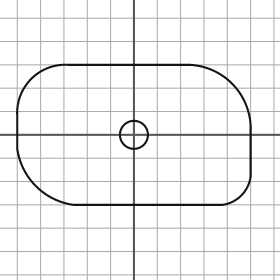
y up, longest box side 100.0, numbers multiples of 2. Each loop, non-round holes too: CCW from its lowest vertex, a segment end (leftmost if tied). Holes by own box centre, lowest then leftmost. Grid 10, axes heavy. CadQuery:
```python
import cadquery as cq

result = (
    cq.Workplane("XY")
    .moveTo(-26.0, -30.0)
    .lineTo(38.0, -30.0)
    .threePointArc((46.0, -26.0), (50.0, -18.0))
    .lineTo(50.0, 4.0)
    .threePointArc((42.0, 22.0), (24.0, 30.0))
    .lineTo(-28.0, 30.0)
    .threePointArc((-44.0, 24.0), (-50.0, 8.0))
    .lineTo(-50.0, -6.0)
    .threePointArc((-42.0, -22.0), (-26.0, -30.0))
    .close()
    .moveTo(0.0, 0.0)
    .circle(6.0)
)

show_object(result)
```